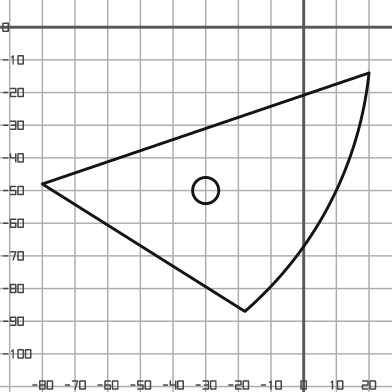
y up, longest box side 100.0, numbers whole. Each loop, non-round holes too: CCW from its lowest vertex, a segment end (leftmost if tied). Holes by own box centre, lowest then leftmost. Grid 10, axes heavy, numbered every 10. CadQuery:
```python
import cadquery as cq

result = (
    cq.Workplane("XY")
    .moveTo(-18.0, -87.0)
    .threePointArc((8.0, -54.0), (20.0, -14.0))
    .lineTo(-80.0, -48.0)
    .close()
    .moveTo(-30.0, -50.0)
    .circle(4.0)
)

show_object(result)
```